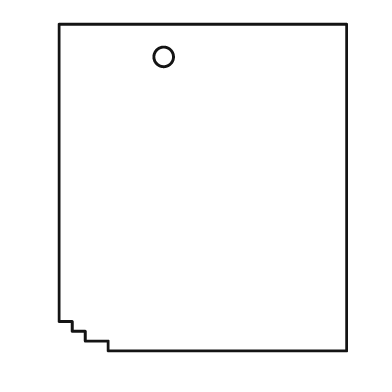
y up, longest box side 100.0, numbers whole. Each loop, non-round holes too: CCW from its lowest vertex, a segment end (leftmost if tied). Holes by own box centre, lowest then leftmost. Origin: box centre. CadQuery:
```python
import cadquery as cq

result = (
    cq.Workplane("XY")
    .moveTo(-29.0, -50.0)
    .lineTo(44.0, -50.0)
    .lineTo(44.0, 50.0)
    .lineTo(-44.0, 50.0)
    .lineTo(-44.0, -41.0)
    .lineTo(-40.0, -41.0)
    .lineTo(-40.0, -44.0)
    .lineTo(-36.0, -44.0)
    .lineTo(-36.0, -47.0)
    .lineTo(-29.0, -47.0)
    .close()
    .moveTo(-12.0, 40.0)
    .circle(3.0)
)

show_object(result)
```